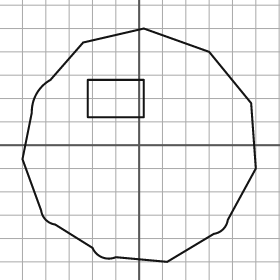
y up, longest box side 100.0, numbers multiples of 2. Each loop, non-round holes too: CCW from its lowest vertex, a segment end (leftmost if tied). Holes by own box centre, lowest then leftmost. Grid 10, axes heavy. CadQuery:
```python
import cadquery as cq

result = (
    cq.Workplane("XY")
    .moveTo(12.0, -50.0)
    .lineTo(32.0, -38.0)
    .threePointArc((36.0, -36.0), (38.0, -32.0))
    .lineTo(50.0, -10.0)
    .lineTo(48.0, 18.0)
    .lineTo(30.0, 40.0)
    .lineTo(2.0, 50.0)
    .lineTo(-24.0, 44.0)
    .lineTo(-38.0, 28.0)
    .threePointArc((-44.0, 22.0), (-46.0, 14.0))
    .lineTo(-50.0, -6.0)
    .lineTo(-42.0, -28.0)
    .threePointArc((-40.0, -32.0), (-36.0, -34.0))
    .lineTo(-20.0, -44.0)
    .threePointArc((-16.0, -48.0), (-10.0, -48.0))
    .close()
    .moveTo(-22.0, 12.0)
    .lineTo(2.0, 12.0)
    .lineTo(2.0, 28.0)
    .lineTo(-22.0, 28.0)
    .close()
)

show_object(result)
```